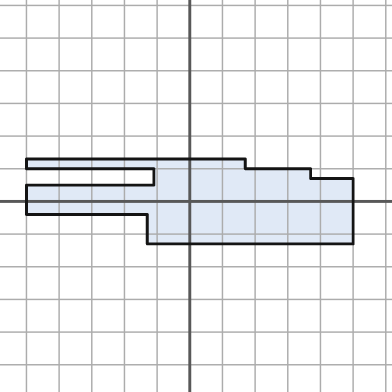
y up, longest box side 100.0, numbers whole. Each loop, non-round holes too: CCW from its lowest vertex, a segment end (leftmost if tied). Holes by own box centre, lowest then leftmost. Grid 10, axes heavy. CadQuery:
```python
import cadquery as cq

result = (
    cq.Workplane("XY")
    .moveTo(-13.0, -13.0)
    .lineTo(50.0, -13.0)
    .lineTo(50.0, 7.0)
    .lineTo(37.0, 7.0)
    .lineTo(37.0, 10.0)
    .lineTo(17.0, 10.0)
    .lineTo(17.0, 13.0)
    .lineTo(-50.0, 13.0)
    .lineTo(-50.0, 10.0)
    .lineTo(-11.0, 10.0)
    .lineTo(-11.0, 5.0)
    .lineTo(-50.0, 5.0)
    .lineTo(-50.0, -4.0)
    .lineTo(-13.0, -4.0)
    .close()
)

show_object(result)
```